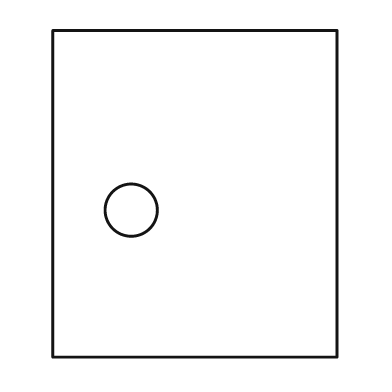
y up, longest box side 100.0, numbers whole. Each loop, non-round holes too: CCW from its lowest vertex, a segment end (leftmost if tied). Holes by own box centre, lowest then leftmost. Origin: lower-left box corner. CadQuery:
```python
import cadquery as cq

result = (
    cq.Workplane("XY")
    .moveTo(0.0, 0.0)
    .lineTo(87.0, 0.0)
    .lineTo(87.0, 100.0)
    .lineTo(0.0, 100.0)
    .close()
    .moveTo(24.0, 45.0)
    .circle(8.0)
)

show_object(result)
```